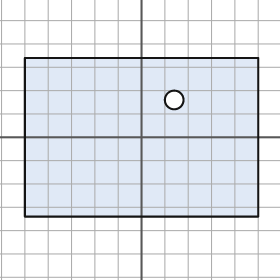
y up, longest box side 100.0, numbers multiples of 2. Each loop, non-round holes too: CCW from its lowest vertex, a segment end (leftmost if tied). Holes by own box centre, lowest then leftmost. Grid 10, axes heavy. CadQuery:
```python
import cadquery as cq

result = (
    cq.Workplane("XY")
    .moveTo(-50.0, -34.0)
    .lineTo(50.0, -34.0)
    .lineTo(50.0, 34.0)
    .lineTo(-50.0, 34.0)
    .close()
    .moveTo(14.0, 16.0)
    .circle(4.0)
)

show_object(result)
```